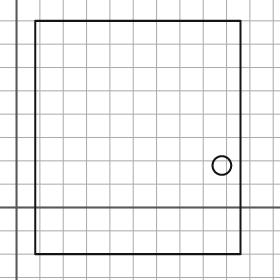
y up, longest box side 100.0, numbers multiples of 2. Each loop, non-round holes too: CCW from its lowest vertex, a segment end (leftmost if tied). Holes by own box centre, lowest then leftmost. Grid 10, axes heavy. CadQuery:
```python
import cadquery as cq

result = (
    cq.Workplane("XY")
    .moveTo(8.0, -20.0)
    .lineTo(96.0, -20.0)
    .lineTo(96.0, 80.0)
    .lineTo(8.0, 80.0)
    .close()
    .moveTo(88.0, 18.0)
    .circle(4.0)
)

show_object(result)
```